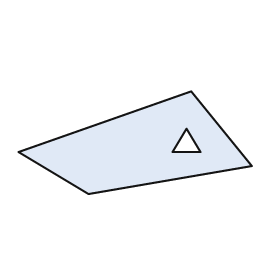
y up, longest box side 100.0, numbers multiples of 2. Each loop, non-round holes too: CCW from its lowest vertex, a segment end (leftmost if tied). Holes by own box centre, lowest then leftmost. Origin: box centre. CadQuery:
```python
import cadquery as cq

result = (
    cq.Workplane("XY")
    .moveTo(-20.0, -22.0)
    .lineTo(50.0, -10.0)
    .lineTo(24.0, 22.0)
    .lineTo(-50.0, -4.0)
    .close()
    .moveTo(16.0, -4.0)
    .lineTo(28.0, -4.0)
    .lineTo(22.0, 6.0)
    .close()
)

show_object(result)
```